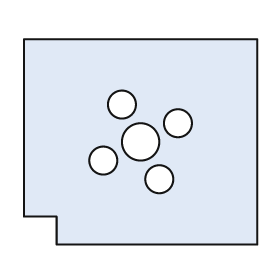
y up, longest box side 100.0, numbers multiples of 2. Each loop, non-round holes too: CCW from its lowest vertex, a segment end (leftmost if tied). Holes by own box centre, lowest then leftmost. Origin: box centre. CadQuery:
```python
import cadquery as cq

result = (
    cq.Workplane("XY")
    .moveTo(-36.0, -44.0)
    .lineTo(50.0, -44.0)
    .lineTo(50.0, 44.0)
    .lineTo(-50.0, 44.0)
    .lineTo(-50.0, -32.0)
    .lineTo(-36.0, -32.0)
    .close()
    .moveTo(8.0, -16.0)
    .circle(6.0)
    .moveTo(-16.0, -8.0)
    .circle(6.0)
    .moveTo(0.0, 0.0)
    .circle(8.0)
    .moveTo(16.0, 8.0)
    .circle(6.0)
    .moveTo(-8.0, 16.0)
    .circle(6.0)
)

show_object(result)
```